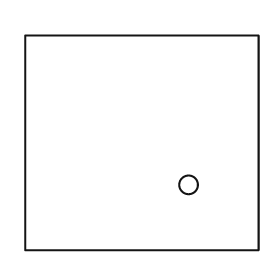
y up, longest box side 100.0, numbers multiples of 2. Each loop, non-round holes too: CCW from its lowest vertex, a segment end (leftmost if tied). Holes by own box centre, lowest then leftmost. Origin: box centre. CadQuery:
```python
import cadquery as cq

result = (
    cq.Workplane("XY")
    .moveTo(-50.0, -46.0)
    .lineTo(50.0, -46.0)
    .lineTo(50.0, 46.0)
    .lineTo(-50.0, 46.0)
    .close()
    .moveTo(20.0, -18.0)
    .circle(4.0)
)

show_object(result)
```